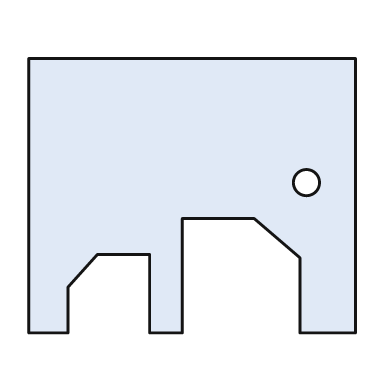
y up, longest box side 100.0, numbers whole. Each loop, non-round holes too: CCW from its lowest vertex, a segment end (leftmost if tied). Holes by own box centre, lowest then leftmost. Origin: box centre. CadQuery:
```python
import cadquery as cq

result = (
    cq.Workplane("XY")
    .moveTo(-50.0, -42.0)
    .lineTo(-38.0, -42.0)
    .lineTo(-38.0, -28.0)
    .lineTo(-29.0, -18.0)
    .lineTo(-13.0, -18.0)
    .lineTo(-13.0, -42.0)
    .lineTo(-3.0, -42.0)
    .lineTo(-3.0, -7.0)
    .lineTo(19.0, -7.0)
    .lineTo(33.0, -19.0)
    .lineTo(33.0, -42.0)
    .lineTo(50.0, -42.0)
    .lineTo(50.0, 42.0)
    .lineTo(-50.0, 42.0)
    .close()
    .moveTo(35.0, 4.0)
    .circle(4.0)
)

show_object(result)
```